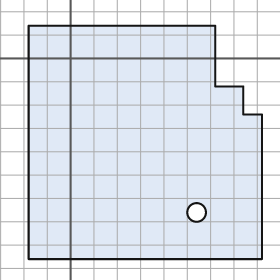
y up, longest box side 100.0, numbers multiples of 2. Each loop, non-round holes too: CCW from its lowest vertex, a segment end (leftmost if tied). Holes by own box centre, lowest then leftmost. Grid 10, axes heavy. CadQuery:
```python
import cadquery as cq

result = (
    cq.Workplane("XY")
    .moveTo(-18.0, -86.0)
    .lineTo(82.0, -86.0)
    .lineTo(82.0, -24.0)
    .lineTo(74.0, -24.0)
    .lineTo(74.0, -12.0)
    .lineTo(62.0, -12.0)
    .lineTo(62.0, 14.0)
    .lineTo(-18.0, 14.0)
    .close()
    .moveTo(54.0, -66.0)
    .circle(4.0)
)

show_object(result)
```